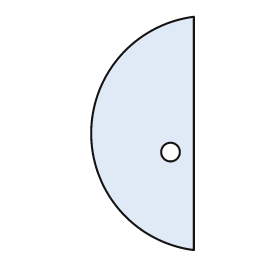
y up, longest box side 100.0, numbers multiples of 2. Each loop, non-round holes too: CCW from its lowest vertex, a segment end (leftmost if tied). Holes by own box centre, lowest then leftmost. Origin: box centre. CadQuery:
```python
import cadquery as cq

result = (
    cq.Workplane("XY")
    .moveTo(22.0, -50.0)
    .lineTo(22.0, 50.0)
    .threePointArc((-22.0, 0.0), (22.0, -50.0))
    .close()
    .moveTo(12.0, -8.0)
    .circle(4.0)
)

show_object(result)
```